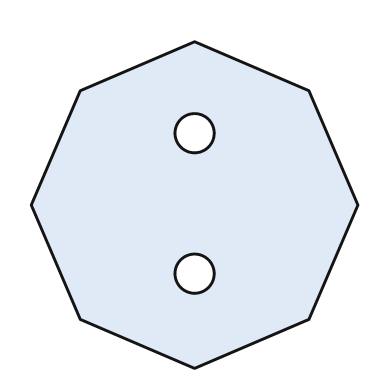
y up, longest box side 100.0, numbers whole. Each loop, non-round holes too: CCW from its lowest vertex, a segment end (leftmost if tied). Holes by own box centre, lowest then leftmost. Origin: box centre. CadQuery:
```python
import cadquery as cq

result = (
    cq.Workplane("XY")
    .moveTo(0.0, -50.0)
    .lineTo(35.0, -35.0)
    .lineTo(50.0, 0.0)
    .lineTo(35.0, 35.0)
    .lineTo(0.0, 50.0)
    .lineTo(-35.0, 35.0)
    .lineTo(-50.0, 0.0)
    .lineTo(-35.0, -35.0)
    .close()
    .moveTo(0.0, -21.0)
    .circle(6.0)
    .moveTo(0.0, 22.0)
    .circle(6.0)
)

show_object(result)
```